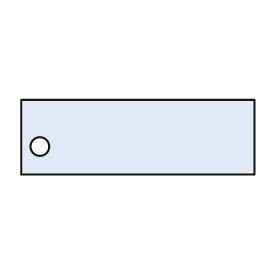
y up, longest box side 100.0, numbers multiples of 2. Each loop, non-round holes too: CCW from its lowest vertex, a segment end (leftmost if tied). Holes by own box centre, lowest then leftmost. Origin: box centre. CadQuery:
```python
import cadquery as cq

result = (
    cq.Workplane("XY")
    .moveTo(-50.0, -16.0)
    .lineTo(50.0, -16.0)
    .lineTo(50.0, 16.0)
    .lineTo(-50.0, 16.0)
    .close()
    .moveTo(-42.0, -4.0)
    .circle(4.0)
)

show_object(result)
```